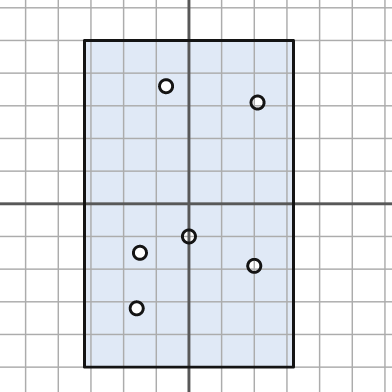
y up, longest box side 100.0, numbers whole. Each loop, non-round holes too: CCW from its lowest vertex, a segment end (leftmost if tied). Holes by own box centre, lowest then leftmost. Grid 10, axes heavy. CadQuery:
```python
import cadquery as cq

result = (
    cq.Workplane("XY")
    .moveTo(-32.0, -50.0)
    .lineTo(32.0, -50.0)
    .lineTo(32.0, 50.0)
    .lineTo(-32.0, 50.0)
    .close()
    .moveTo(-16.0, -32.0)
    .circle(2.0)
    .moveTo(20.0, -19.0)
    .circle(2.0)
    .moveTo(-15.0, -15.0)
    .circle(2.0)
    .moveTo(0.0, -10.0)
    .circle(2.0)
    .moveTo(21.0, 31.0)
    .circle(2.0)
    .moveTo(-7.0, 36.0)
    .circle(2.0)
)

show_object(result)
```